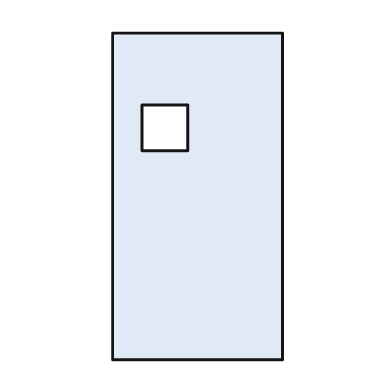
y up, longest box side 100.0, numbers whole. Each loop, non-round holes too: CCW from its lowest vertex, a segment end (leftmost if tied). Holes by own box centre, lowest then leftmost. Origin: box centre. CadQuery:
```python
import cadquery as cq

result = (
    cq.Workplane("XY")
    .moveTo(-26.0, -50.0)
    .lineTo(26.0, -50.0)
    .lineTo(26.0, 50.0)
    .lineTo(-26.0, 50.0)
    .close()
    .moveTo(-17.0, 14.0)
    .lineTo(-3.0, 14.0)
    .lineTo(-3.0, 28.0)
    .lineTo(-17.0, 28.0)
    .close()
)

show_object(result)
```